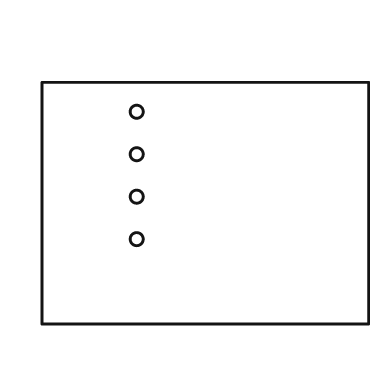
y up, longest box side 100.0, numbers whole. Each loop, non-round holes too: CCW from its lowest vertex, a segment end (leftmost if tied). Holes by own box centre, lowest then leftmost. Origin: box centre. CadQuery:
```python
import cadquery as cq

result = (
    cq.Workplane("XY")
    .moveTo(-50.0, -37.0)
    .lineTo(50.0, -37.0)
    .lineTo(50.0, 37.0)
    .lineTo(-50.0, 37.0)
    .close()
    .moveTo(-21.0, -11.0)
    .circle(2.0)
    .moveTo(-21.0, 2.0)
    .circle(2.0)
    .moveTo(-21.0, 15.0)
    .circle(2.0)
    .moveTo(-21.0, 28.0)
    .circle(2.0)
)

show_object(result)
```